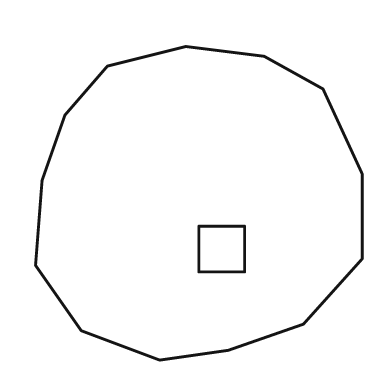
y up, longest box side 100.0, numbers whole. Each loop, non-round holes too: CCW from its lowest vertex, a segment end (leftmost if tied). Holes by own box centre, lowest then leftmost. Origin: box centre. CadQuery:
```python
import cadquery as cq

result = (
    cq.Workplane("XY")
    .moveTo(-12.0, -48.0)
    .lineTo(9.0, -45.0)
    .lineTo(32.0, -37.0)
    .lineTo(50.0, -17.0)
    .lineTo(50.0, 9.0)
    .lineTo(38.0, 35.0)
    .lineTo(20.0, 45.0)
    .lineTo(-4.0, 48.0)
    .lineTo(-28.0, 42.0)
    .lineTo(-41.0, 27.0)
    .lineTo(-48.0, 7.0)
    .lineTo(-50.0, -19.0)
    .lineTo(-36.0, -39.0)
    .close()
    .moveTo(0.0, -21.0)
    .lineTo(14.0, -21.0)
    .lineTo(14.0, -7.0)
    .lineTo(0.0, -7.0)
    .close()
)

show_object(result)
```